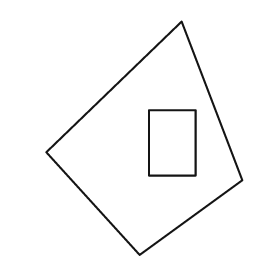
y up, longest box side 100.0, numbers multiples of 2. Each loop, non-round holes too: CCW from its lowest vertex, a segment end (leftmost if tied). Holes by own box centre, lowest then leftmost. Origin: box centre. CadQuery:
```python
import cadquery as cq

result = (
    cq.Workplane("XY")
    .moveTo(-2.0, -50.0)
    .lineTo(42.0, -18.0)
    .lineTo(16.0, 50.0)
    .lineTo(-42.0, -6.0)
    .close()
    .moveTo(2.0, -16.0)
    .lineTo(22.0, -16.0)
    .lineTo(22.0, 12.0)
    .lineTo(2.0, 12.0)
    .close()
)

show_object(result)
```